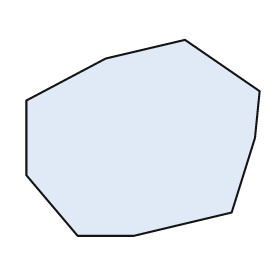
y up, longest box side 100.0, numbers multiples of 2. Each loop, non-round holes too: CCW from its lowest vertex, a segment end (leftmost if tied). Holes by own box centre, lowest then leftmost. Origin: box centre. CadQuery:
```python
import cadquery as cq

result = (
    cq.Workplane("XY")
    .moveTo(-28.0, -42.0)
    .lineTo(-4.0, -42.0)
    .lineTo(38.0, -32.0)
    .lineTo(48.0, 0.0)
    .lineTo(50.0, 20.0)
    .lineTo(18.0, 42.0)
    .lineTo(-16.0, 34.0)
    .lineTo(-50.0, 16.0)
    .lineTo(-50.0, -16.0)
    .close()
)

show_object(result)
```